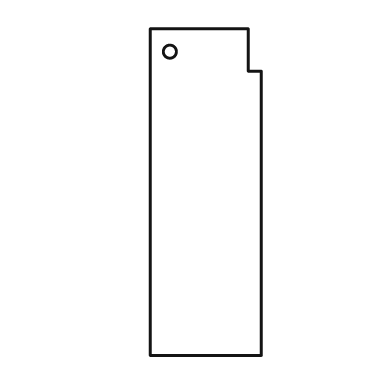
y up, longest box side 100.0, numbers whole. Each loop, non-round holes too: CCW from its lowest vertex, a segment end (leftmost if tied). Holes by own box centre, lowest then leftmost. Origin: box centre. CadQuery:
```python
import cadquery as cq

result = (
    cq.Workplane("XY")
    .moveTo(-17.0, -50.0)
    .lineTo(17.0, -50.0)
    .lineTo(17.0, 37.0)
    .lineTo(13.0, 37.0)
    .lineTo(13.0, 50.0)
    .lineTo(-17.0, 50.0)
    .close()
    .moveTo(-11.0, 43.0)
    .circle(2.0)
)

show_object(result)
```